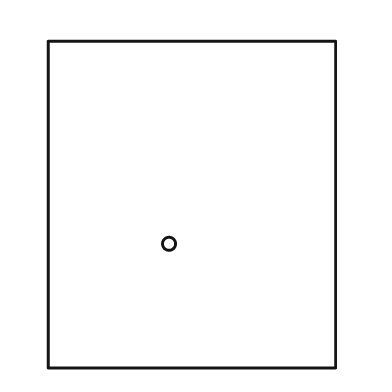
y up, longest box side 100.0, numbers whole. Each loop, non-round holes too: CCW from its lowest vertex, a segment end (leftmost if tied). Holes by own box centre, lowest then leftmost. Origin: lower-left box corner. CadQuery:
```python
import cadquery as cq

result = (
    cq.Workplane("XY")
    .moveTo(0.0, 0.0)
    .lineTo(88.0, 0.0)
    .lineTo(88.0, 100.0)
    .lineTo(0.0, 100.0)
    .close()
    .moveTo(37.0, 38.0)
    .circle(2.0)
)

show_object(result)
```